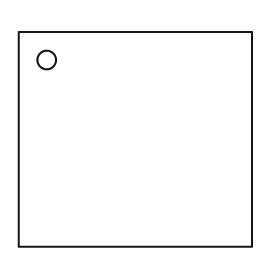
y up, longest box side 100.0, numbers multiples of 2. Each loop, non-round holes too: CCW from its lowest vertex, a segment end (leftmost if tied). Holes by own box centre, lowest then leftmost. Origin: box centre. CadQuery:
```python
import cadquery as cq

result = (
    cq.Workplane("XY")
    .moveTo(-50.0, -46.0)
    .lineTo(50.0, -46.0)
    .lineTo(50.0, 46.0)
    .lineTo(-50.0, 46.0)
    .close()
    .moveTo(-38.0, 34.0)
    .circle(4.0)
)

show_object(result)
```